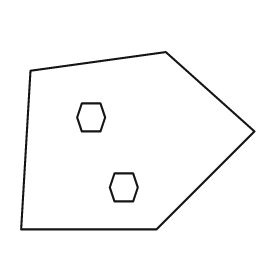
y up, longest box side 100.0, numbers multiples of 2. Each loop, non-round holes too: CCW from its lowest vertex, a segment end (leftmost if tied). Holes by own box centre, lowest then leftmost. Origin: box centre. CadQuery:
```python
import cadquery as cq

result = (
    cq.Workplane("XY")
    .moveTo(-50.0, -38.0)
    .lineTo(8.0, -38.0)
    .lineTo(50.0, 4.0)
    .lineTo(12.0, 38.0)
    .lineTo(-46.0, 30.0)
    .close()
    .moveTo(-10.0, -26.0)
    .lineTo(-2.0, -26.0)
    .lineTo(0.0, -20.0)
    .lineTo(-2.0, -14.0)
    .lineTo(-10.0, -14.0)
    .lineTo(-12.0, -20.0)
    .close()
    .moveTo(-24.0, 4.0)
    .lineTo(-16.0, 4.0)
    .lineTo(-14.0, 10.0)
    .lineTo(-16.0, 16.0)
    .lineTo(-24.0, 16.0)
    .lineTo(-26.0, 10.0)
    .close()
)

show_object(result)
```